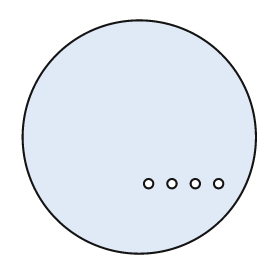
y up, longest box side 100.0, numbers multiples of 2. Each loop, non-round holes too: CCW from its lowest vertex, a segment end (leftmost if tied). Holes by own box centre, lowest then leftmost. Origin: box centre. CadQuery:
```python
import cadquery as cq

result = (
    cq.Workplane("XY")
    .moveTo(0.0, 0.0)
    .circle(50.0)
    .moveTo(4.0, -20.0)
    .circle(2.0)
    .moveTo(14.0, -20.0)
    .circle(2.0)
    .moveTo(24.0, -20.0)
    .circle(2.0)
    .moveTo(34.0, -20.0)
    .circle(2.0)
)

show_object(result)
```